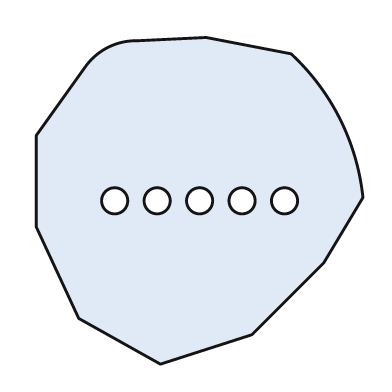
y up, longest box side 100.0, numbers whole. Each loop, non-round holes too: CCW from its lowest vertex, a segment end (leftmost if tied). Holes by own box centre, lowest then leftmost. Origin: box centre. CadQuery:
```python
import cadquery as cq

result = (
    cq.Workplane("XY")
    .moveTo(-12.0, -50.0)
    .lineTo(16.0, -41.0)
    .lineTo(38.0, -19.0)
    .lineTo(50.0, 1.0)
    .threePointArc((43.0, 25.0), (28.0, 45.0))
    .lineTo(2.0, 50.0)
    .lineTo(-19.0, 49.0)
    .threePointArc((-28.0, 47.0), (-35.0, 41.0))
    .lineTo(-50.0, 20.0)
    .lineTo(-50.0, -8.0)
    .lineTo(-37.0, -36.0)
    .close()
    .moveTo(-26.0, 0.0)
    .circle(4.0)
    .moveTo(-13.0, 0.0)
    .circle(4.0)
    .moveTo(0.0, 0.0)
    .circle(4.0)
    .moveTo(13.0, 0.0)
    .circle(4.0)
    .moveTo(26.0, 0.0)
    .circle(4.0)
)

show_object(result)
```